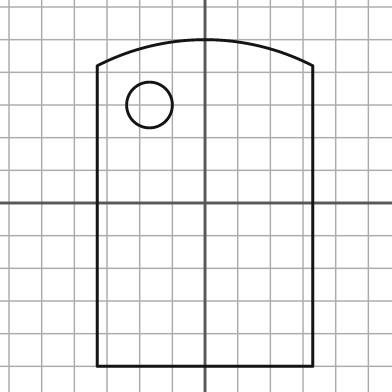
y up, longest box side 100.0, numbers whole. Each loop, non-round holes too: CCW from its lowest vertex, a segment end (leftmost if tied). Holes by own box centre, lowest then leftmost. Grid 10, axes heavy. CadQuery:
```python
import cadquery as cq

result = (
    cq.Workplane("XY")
    .moveTo(-33.0, -50.0)
    .lineTo(33.0, -50.0)
    .lineTo(33.0, 42.0)
    .threePointArc((0.0, 50.0), (-33.0, 42.0))
    .close()
    .moveTo(-17.0, 30.0)
    .circle(7.0)
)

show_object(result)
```